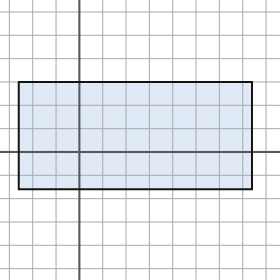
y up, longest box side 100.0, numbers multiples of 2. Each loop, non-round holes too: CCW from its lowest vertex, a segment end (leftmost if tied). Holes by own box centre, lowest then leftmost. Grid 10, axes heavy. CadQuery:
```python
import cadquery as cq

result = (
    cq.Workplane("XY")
    .moveTo(-26.0, -16.0)
    .lineTo(74.0, -16.0)
    .lineTo(74.0, 30.0)
    .lineTo(-26.0, 30.0)
    .close()
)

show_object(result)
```